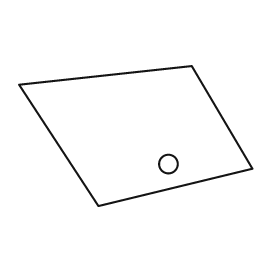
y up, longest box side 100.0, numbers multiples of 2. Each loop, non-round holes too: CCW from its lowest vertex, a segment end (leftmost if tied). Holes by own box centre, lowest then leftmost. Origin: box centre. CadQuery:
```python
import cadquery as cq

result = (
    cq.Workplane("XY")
    .moveTo(-16.0, -30.0)
    .lineTo(50.0, -14.0)
    .lineTo(24.0, 30.0)
    .lineTo(-50.0, 22.0)
    .close()
    .moveTo(14.0, -12.0)
    .circle(4.0)
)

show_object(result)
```